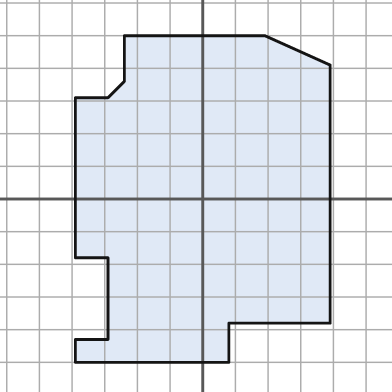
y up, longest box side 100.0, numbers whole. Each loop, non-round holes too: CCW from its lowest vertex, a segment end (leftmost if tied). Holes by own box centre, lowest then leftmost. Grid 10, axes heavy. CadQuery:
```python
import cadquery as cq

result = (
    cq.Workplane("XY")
    .moveTo(-39.0, -50.0)
    .lineTo(8.0, -50.0)
    .lineTo(8.0, -38.0)
    .lineTo(39.0, -38.0)
    .lineTo(39.0, 41.0)
    .lineTo(19.0, 50.0)
    .lineTo(-24.0, 50.0)
    .lineTo(-24.0, 36.0)
    .lineTo(-29.0, 31.0)
    .lineTo(-39.0, 31.0)
    .lineTo(-39.0, -18.0)
    .lineTo(-29.0, -18.0)
    .lineTo(-29.0, -43.0)
    .lineTo(-39.0, -43.0)
    .close()
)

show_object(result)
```